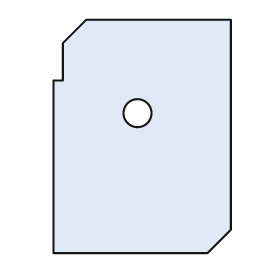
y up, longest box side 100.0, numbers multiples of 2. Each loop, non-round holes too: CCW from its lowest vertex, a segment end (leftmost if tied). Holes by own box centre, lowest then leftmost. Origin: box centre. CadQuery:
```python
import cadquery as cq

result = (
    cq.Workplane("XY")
    .moveTo(-38.0, -50.0)
    .lineTo(28.0, -50.0)
    .lineTo(38.0, -40.0)
    .lineTo(38.0, 50.0)
    .lineTo(-24.0, 50.0)
    .lineTo(-34.0, 40.0)
    .lineTo(-34.0, 24.0)
    .lineTo(-38.0, 24.0)
    .close()
    .moveTo(-2.0, 10.0)
    .circle(6.0)
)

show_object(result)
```